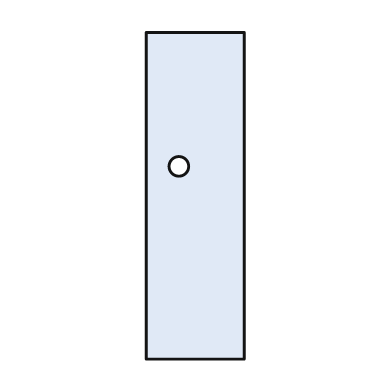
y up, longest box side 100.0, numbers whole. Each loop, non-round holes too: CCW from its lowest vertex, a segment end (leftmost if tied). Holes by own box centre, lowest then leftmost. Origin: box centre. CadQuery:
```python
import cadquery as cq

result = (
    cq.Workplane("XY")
    .moveTo(-15.0, -50.0)
    .lineTo(15.0, -50.0)
    .lineTo(15.0, 50.0)
    .lineTo(-15.0, 50.0)
    .close()
    .moveTo(-5.0, 9.0)
    .circle(3.0)
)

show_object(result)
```